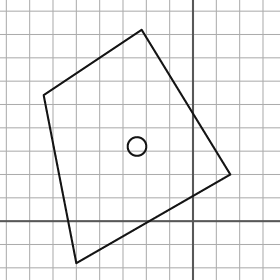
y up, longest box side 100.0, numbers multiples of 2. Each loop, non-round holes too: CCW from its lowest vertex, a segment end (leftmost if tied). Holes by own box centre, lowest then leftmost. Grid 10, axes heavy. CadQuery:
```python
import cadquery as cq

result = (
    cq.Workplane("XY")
    .moveTo(-50.0, -18.0)
    .lineTo(16.0, 20.0)
    .lineTo(-22.0, 82.0)
    .lineTo(-64.0, 54.0)
    .close()
    .moveTo(-24.0, 32.0)
    .circle(4.0)
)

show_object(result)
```